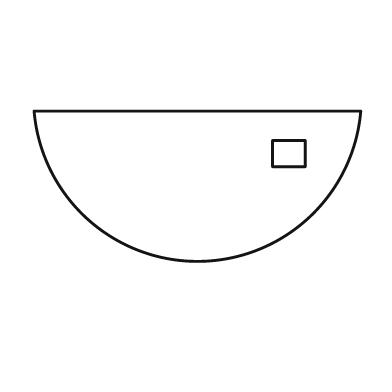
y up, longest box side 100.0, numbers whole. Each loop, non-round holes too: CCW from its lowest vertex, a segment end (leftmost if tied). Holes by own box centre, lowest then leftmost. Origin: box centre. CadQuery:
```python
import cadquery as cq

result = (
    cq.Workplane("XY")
    .moveTo(-50.0, 23.0)
    .threePointArc((0.0, -23.0), (50.0, 23.0))
    .close()
    .moveTo(23.0, 6.0)
    .lineTo(33.0, 6.0)
    .lineTo(33.0, 14.0)
    .lineTo(23.0, 14.0)
    .close()
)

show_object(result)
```